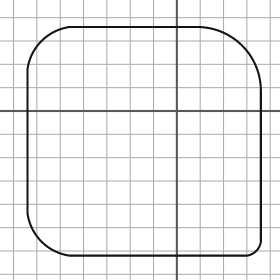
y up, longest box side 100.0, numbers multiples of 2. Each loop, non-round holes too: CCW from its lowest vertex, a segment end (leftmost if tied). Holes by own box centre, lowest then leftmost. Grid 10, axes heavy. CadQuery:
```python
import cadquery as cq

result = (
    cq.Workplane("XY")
    .moveTo(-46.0, -62.0)
    .lineTo(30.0, -62.0)
    .threePointArc((34.0, -60.0), (36.0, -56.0))
    .lineTo(36.0, 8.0)
    .threePointArc((28.0, 28.0), (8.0, 36.0))
    .lineTo(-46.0, 36.0)
    .threePointArc((-58.0, 30.0), (-64.0, 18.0))
    .lineTo(-64.0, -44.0)
    .threePointArc((-58.0, -56.0), (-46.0, -62.0))
    .close()
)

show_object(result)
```